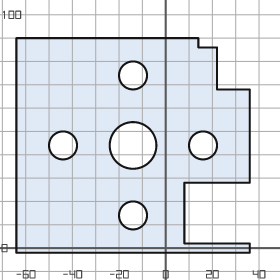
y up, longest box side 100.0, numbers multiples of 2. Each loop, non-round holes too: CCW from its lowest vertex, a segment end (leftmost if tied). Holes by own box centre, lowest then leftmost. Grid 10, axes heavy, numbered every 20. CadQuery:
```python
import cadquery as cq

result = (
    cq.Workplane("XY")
    .moveTo(-64.0, -2.0)
    .lineTo(36.0, -2.0)
    .lineTo(36.0, 2.0)
    .lineTo(8.0, 2.0)
    .lineTo(8.0, 28.0)
    .lineTo(36.0, 28.0)
    .lineTo(36.0, 68.0)
    .lineTo(22.0, 68.0)
    .lineTo(22.0, 86.0)
    .lineTo(14.0, 86.0)
    .lineTo(14.0, 90.0)
    .lineTo(-64.0, 90.0)
    .close()
    .moveTo(-14.0, 14.0)
    .circle(6.0)
    .moveTo(-44.0, 44.0)
    .circle(6.0)
    .moveTo(-14.0, 44.0)
    .circle(10.0)
    .moveTo(16.0, 44.0)
    .circle(6.0)
    .moveTo(-14.0, 74.0)
    .circle(6.0)
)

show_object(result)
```